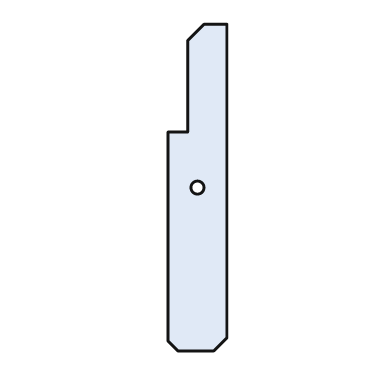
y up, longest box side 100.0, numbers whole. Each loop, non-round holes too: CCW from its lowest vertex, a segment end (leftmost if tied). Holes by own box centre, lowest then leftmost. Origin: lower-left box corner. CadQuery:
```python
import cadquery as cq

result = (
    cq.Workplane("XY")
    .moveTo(3.0, 0.0)
    .lineTo(14.0, 0.0)
    .lineTo(18.0, 4.0)
    .lineTo(18.0, 100.0)
    .lineTo(11.0, 100.0)
    .lineTo(6.0, 95.0)
    .lineTo(6.0, 67.0)
    .lineTo(0.0, 67.0)
    .lineTo(0.0, 3.0)
    .close()
    .moveTo(9.0, 50.0)
    .circle(2.0)
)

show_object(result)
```